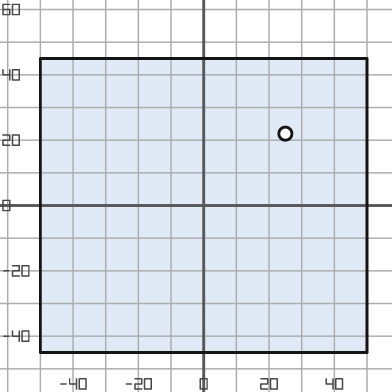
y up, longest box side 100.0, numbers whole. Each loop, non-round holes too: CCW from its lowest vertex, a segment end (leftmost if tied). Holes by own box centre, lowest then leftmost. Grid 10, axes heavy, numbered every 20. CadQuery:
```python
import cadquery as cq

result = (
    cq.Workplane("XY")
    .moveTo(-50.0, -45.0)
    .lineTo(50.0, -45.0)
    .lineTo(50.0, 45.0)
    .lineTo(-50.0, 45.0)
    .close()
    .moveTo(25.0, 22.0)
    .circle(2.0)
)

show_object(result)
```